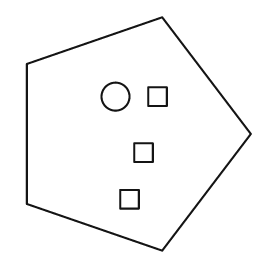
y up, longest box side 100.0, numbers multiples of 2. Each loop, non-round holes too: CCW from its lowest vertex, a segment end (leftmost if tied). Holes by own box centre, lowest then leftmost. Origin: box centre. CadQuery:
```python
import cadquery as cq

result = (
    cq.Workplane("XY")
    .moveTo(10.0, -50.0)
    .lineTo(48.0, 0.0)
    .lineTo(10.0, 50.0)
    .lineTo(-48.0, 30.0)
    .lineTo(-48.0, -30.0)
    .close()
    .moveTo(-8.0, -32.0)
    .lineTo(0.0, -32.0)
    .lineTo(0.0, -24.0)
    .lineTo(-8.0, -24.0)
    .close()
    .moveTo(-2.0, -12.0)
    .lineTo(6.0, -12.0)
    .lineTo(6.0, -4.0)
    .lineTo(-2.0, -4.0)
    .close()
    .moveTo(-10.0, 16.0)
    .circle(6.0)
    .moveTo(4.0, 12.0)
    .lineTo(12.0, 12.0)
    .lineTo(12.0, 20.0)
    .lineTo(4.0, 20.0)
    .close()
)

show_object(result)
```